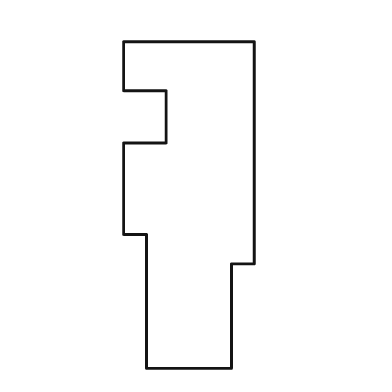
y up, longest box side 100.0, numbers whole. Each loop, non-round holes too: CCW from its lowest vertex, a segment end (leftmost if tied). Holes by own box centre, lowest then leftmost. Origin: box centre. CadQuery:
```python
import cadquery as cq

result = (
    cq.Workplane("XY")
    .moveTo(-13.0, -50.0)
    .lineTo(13.0, -50.0)
    .lineTo(13.0, -18.0)
    .lineTo(20.0, -18.0)
    .lineTo(20.0, 50.0)
    .lineTo(-20.0, 50.0)
    .lineTo(-20.0, 35.0)
    .lineTo(-7.0, 35.0)
    .lineTo(-7.0, 19.0)
    .lineTo(-20.0, 19.0)
    .lineTo(-20.0, -9.0)
    .lineTo(-13.0, -9.0)
    .close()
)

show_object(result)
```